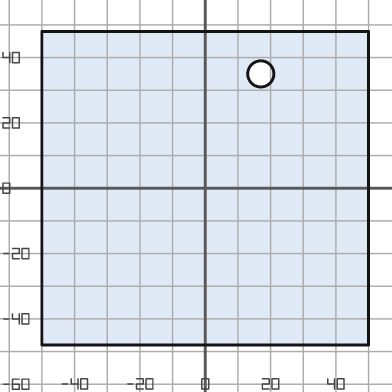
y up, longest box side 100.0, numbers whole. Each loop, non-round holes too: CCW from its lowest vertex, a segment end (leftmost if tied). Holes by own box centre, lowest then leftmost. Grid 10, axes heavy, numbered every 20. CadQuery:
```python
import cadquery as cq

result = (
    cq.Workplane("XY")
    .moveTo(-50.0, -48.0)
    .lineTo(50.0, -48.0)
    .lineTo(50.0, 48.0)
    .lineTo(-50.0, 48.0)
    .close()
    .moveTo(17.0, 35.0)
    .circle(4.0)
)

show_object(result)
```